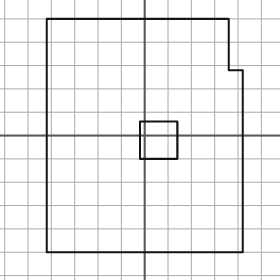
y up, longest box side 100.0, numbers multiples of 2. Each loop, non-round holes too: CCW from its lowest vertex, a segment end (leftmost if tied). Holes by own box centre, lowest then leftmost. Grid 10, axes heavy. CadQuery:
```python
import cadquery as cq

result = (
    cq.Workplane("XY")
    .moveTo(-42.0, -50.0)
    .lineTo(42.0, -50.0)
    .lineTo(42.0, 28.0)
    .lineTo(36.0, 28.0)
    .lineTo(36.0, 50.0)
    .lineTo(-42.0, 50.0)
    .close()
    .moveTo(-2.0, -10.0)
    .lineTo(14.0, -10.0)
    .lineTo(14.0, 6.0)
    .lineTo(-2.0, 6.0)
    .close()
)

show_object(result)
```